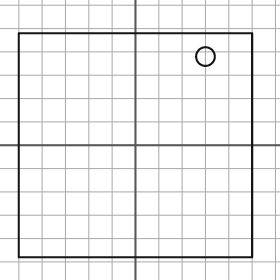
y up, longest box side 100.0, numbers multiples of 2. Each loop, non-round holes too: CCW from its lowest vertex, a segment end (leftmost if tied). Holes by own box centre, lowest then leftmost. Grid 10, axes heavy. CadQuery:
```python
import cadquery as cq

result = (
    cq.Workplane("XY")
    .moveTo(-50.0, -48.0)
    .lineTo(50.0, -48.0)
    .lineTo(50.0, 48.0)
    .lineTo(-50.0, 48.0)
    .close()
    .moveTo(30.0, 38.0)
    .circle(4.0)
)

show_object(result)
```